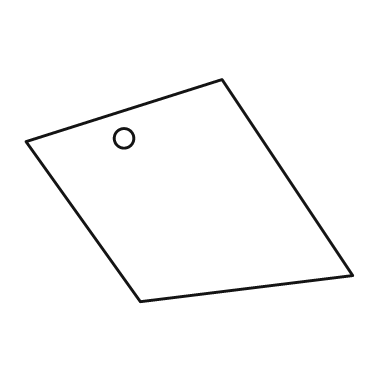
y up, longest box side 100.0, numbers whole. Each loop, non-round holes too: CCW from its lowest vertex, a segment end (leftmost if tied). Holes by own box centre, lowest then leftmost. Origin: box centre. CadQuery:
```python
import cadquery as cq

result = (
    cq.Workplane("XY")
    .moveTo(-15.0, -34.0)
    .lineTo(50.0, -26.0)
    .lineTo(10.0, 34.0)
    .lineTo(-50.0, 15.0)
    .close()
    .moveTo(-20.0, 16.0)
    .circle(3.0)
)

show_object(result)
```